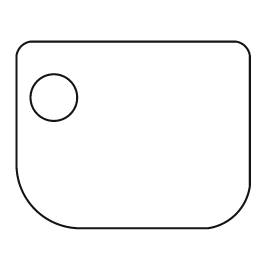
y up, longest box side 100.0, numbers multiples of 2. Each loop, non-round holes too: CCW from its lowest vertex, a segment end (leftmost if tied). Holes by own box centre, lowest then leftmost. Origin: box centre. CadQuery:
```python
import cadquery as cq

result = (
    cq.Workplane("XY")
    .moveTo(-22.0, -40.0)
    .lineTo(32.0, -40.0)
    .threePointArc((44.0, -34.0), (50.0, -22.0))
    .lineTo(50.0, 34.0)
    .threePointArc((48.0, 38.0), (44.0, 40.0))
    .lineTo(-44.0, 40.0)
    .threePointArc((-48.0, 38.0), (-50.0, 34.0))
    .lineTo(-50.0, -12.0)
    .threePointArc((-42.0, -32.0), (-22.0, -40.0))
    .close()
    .moveTo(-34.0, 16.0)
    .circle(10.0)
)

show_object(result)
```